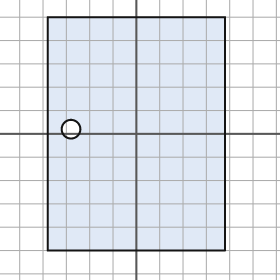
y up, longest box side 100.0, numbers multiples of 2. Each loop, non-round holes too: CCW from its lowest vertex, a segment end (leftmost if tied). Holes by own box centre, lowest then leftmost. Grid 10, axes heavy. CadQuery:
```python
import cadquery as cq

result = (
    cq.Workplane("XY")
    .moveTo(-38.0, -50.0)
    .lineTo(38.0, -50.0)
    .lineTo(38.0, 50.0)
    .lineTo(-38.0, 50.0)
    .close()
    .moveTo(-28.0, 2.0)
    .circle(4.0)
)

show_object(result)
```